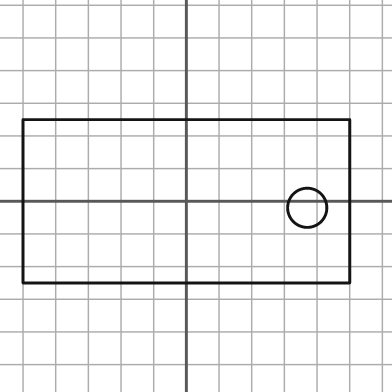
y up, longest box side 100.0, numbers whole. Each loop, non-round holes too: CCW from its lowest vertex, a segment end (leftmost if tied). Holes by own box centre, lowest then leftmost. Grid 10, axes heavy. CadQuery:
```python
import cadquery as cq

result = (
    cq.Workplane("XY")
    .moveTo(-50.0, -25.0)
    .lineTo(50.0, -25.0)
    .lineTo(50.0, 25.0)
    .lineTo(-50.0, 25.0)
    .close()
    .moveTo(37.0, -2.0)
    .circle(6.0)
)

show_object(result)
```